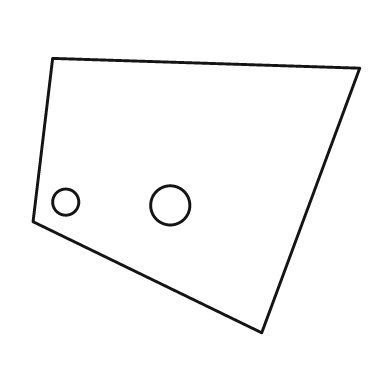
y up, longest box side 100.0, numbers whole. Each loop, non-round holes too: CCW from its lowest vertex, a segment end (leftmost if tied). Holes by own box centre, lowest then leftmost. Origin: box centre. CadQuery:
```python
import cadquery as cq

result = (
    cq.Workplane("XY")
    .moveTo(20.0, -42.0)
    .lineTo(50.0, 39.0)
    .lineTo(-44.0, 42.0)
    .lineTo(-50.0, -8.0)
    .close()
    .moveTo(-8.0, -3.0)
    .circle(6.0)
    .moveTo(-40.0, -2.0)
    .circle(4.0)
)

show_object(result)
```